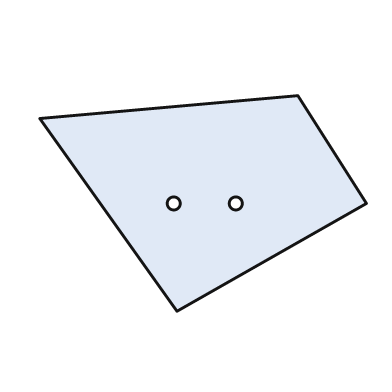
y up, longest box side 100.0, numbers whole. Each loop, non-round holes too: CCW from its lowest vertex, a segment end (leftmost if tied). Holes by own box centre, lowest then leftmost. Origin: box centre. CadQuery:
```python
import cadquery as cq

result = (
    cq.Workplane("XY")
    .moveTo(-8.0, -33.0)
    .lineTo(50.0, 0.0)
    .lineTo(29.0, 33.0)
    .lineTo(-50.0, 26.0)
    .close()
    .moveTo(-9.0, 0.0)
    .circle(2.0)
    .moveTo(10.0, 0.0)
    .circle(2.0)
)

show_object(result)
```